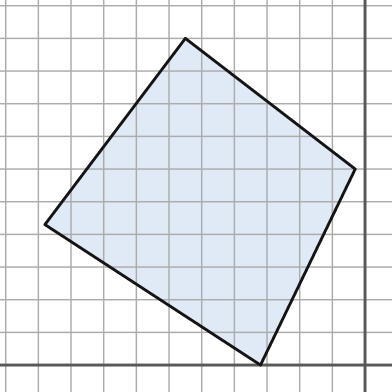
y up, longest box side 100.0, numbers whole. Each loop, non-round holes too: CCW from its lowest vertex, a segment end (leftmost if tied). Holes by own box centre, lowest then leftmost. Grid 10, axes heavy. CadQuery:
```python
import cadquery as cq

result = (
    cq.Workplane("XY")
    .moveTo(-32.0, 0.0)
    .lineTo(-3.0, 60.0)
    .lineTo(-55.0, 100.0)
    .lineTo(-98.0, 43.0)
    .close()
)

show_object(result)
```